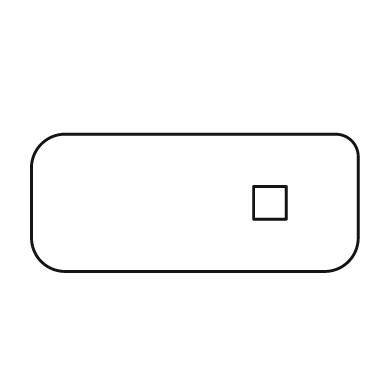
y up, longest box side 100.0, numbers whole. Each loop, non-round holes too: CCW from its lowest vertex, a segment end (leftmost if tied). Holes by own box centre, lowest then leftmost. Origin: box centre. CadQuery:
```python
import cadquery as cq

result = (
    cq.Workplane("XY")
    .moveTo(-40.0, -21.0)
    .lineTo(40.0, -21.0)
    .threePointArc((47.0, -18.0), (50.0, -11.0))
    .lineTo(50.0, 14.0)
    .threePointArc((48.0, 19.0), (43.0, 21.0))
    .lineTo(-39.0, 21.0)
    .threePointArc((-47.0, 18.0), (-50.0, 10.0))
    .lineTo(-50.0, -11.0)
    .threePointArc((-47.0, -18.0), (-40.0, -21.0))
    .close()
    .moveTo(18.0, -5.0)
    .lineTo(28.0, -5.0)
    .lineTo(28.0, 5.0)
    .lineTo(18.0, 5.0)
    .close()
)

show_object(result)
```